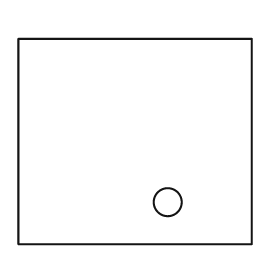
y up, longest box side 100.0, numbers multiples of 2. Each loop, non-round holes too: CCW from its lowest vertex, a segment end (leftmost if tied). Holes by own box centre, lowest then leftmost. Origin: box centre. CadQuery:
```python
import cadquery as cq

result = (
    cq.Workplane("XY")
    .moveTo(-50.0, -44.0)
    .lineTo(50.0, -44.0)
    .lineTo(50.0, 44.0)
    .lineTo(-50.0, 44.0)
    .close()
    .moveTo(14.0, -26.0)
    .circle(6.0)
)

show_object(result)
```